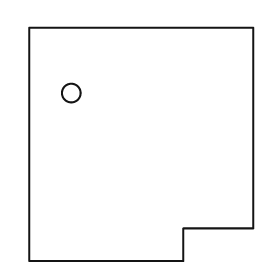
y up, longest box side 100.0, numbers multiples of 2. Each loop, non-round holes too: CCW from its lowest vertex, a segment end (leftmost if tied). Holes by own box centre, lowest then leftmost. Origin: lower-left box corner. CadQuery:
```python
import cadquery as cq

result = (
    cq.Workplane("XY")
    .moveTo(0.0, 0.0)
    .lineTo(66.0, 0.0)
    .lineTo(66.0, 14.0)
    .lineTo(96.0, 14.0)
    .lineTo(96.0, 100.0)
    .lineTo(0.0, 100.0)
    .close()
    .moveTo(18.0, 72.0)
    .circle(4.0)
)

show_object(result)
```